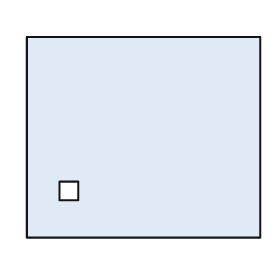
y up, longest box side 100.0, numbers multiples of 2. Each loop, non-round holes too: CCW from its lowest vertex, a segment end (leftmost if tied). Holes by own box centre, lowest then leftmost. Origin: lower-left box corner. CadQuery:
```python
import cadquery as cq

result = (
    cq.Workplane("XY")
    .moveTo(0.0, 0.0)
    .lineTo(100.0, 0.0)
    .lineTo(100.0, 86.0)
    .lineTo(0.0, 86.0)
    .close()
    .moveTo(14.0, 16.0)
    .lineTo(22.0, 16.0)
    .lineTo(22.0, 24.0)
    .lineTo(14.0, 24.0)
    .close()
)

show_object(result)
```